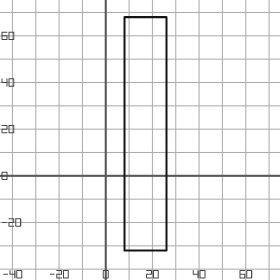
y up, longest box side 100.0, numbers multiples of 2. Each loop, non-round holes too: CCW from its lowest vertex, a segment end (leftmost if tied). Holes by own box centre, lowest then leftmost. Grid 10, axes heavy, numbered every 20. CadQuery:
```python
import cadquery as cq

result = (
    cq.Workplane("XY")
    .moveTo(8.0, -32.0)
    .lineTo(26.0, -32.0)
    .lineTo(26.0, 68.0)
    .lineTo(8.0, 68.0)
    .close()
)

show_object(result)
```